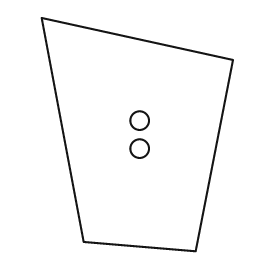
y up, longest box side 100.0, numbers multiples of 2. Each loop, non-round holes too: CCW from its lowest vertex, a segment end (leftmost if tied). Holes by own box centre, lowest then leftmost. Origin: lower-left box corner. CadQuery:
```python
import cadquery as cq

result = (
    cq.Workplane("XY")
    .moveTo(66.0, 0.0)
    .lineTo(82.0, 82.0)
    .lineTo(0.0, 100.0)
    .lineTo(18.0, 4.0)
    .close()
    .moveTo(42.0, 44.0)
    .circle(4.0)
    .moveTo(42.0, 56.0)
    .circle(4.0)
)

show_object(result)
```